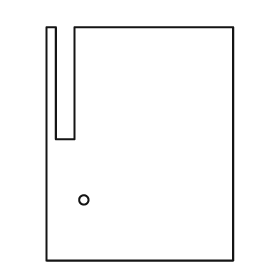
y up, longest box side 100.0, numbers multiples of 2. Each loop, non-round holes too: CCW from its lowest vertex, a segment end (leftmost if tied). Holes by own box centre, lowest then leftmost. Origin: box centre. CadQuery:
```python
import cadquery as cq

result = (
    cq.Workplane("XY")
    .moveTo(-40.0, -50.0)
    .lineTo(40.0, -50.0)
    .lineTo(40.0, 50.0)
    .lineTo(-28.0, 50.0)
    .lineTo(-28.0, 2.0)
    .lineTo(-36.0, 2.0)
    .lineTo(-36.0, 50.0)
    .lineTo(-40.0, 50.0)
    .close()
    .moveTo(-24.0, -24.0)
    .circle(2.0)
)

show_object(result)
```